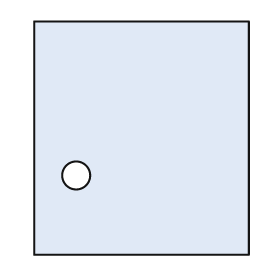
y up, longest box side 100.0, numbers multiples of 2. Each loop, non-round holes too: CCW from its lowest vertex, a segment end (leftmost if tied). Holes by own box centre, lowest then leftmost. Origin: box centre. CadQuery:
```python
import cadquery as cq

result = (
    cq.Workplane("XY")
    .moveTo(-46.0, -50.0)
    .lineTo(46.0, -50.0)
    .lineTo(46.0, 50.0)
    .lineTo(-46.0, 50.0)
    .close()
    .moveTo(-28.0, -16.0)
    .circle(6.0)
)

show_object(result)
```